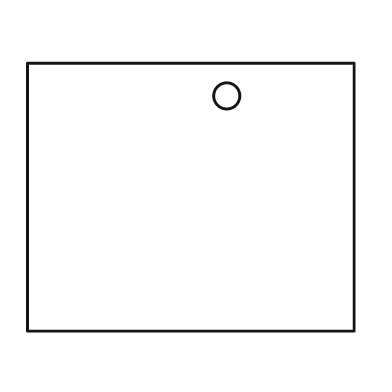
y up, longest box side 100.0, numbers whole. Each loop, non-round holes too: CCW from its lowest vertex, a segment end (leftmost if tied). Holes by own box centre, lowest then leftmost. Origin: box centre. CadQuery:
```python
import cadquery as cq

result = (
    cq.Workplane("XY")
    .moveTo(-50.0, -41.0)
    .lineTo(50.0, -41.0)
    .lineTo(50.0, 41.0)
    .lineTo(-50.0, 41.0)
    .close()
    .moveTo(11.0, 31.0)
    .circle(4.0)
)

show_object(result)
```